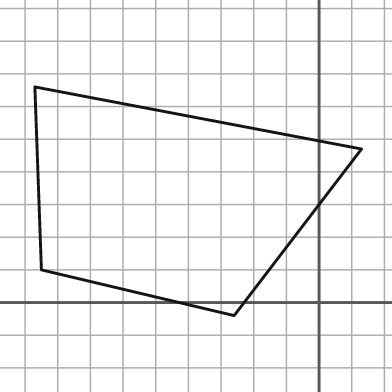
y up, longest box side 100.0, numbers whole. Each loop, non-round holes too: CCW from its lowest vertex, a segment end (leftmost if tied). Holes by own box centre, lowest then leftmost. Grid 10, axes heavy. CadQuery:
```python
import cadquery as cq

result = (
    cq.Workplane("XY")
    .moveTo(-26.0, -4.0)
    .lineTo(13.0, 47.0)
    .lineTo(-87.0, 66.0)
    .lineTo(-85.0, 10.0)
    .close()
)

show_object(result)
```